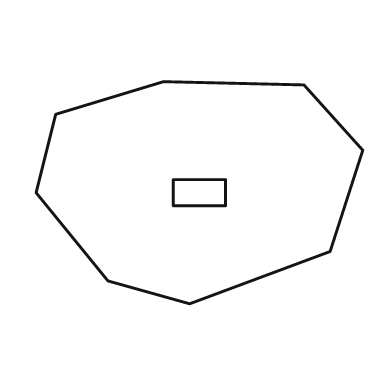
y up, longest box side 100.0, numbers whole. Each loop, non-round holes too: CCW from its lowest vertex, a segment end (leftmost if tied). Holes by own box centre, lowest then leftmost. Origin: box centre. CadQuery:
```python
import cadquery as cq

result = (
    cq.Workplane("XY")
    .moveTo(-3.0, -34.0)
    .lineTo(40.0, -18.0)
    .lineTo(50.0, 13.0)
    .lineTo(32.0, 33.0)
    .lineTo(-11.0, 34.0)
    .lineTo(-44.0, 24.0)
    .lineTo(-50.0, 0.0)
    .lineTo(-28.0, -27.0)
    .close()
    .moveTo(-8.0, -4.0)
    .lineTo(8.0, -4.0)
    .lineTo(8.0, 4.0)
    .lineTo(-8.0, 4.0)
    .close()
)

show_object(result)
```